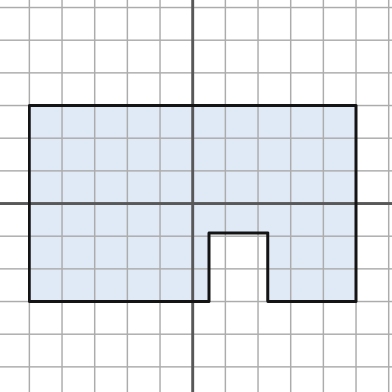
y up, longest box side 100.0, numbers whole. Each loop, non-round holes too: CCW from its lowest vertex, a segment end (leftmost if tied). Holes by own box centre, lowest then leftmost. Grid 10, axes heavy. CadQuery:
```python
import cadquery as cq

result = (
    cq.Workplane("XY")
    .moveTo(-50.0, -30.0)
    .lineTo(5.0, -30.0)
    .lineTo(5.0, -9.0)
    .lineTo(23.0, -9.0)
    .lineTo(23.0, -30.0)
    .lineTo(50.0, -30.0)
    .lineTo(50.0, 30.0)
    .lineTo(-50.0, 30.0)
    .close()
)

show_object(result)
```